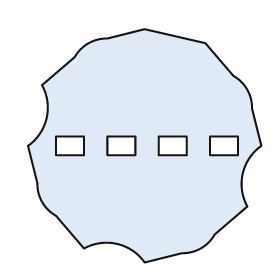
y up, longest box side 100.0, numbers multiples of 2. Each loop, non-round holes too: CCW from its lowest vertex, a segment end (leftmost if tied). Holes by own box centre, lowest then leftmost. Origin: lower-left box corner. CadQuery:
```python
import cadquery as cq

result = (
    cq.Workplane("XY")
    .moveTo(50.0, 0.0)
    .lineTo(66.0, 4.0)
    .threePointArc((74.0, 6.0), (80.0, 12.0))
    .lineTo(94.0, 24.0)
    .threePointArc((92.0, 38.0), (100.0, 50.0))
    .lineTo(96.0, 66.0)
    .threePointArc((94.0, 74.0), (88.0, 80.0))
    .lineTo(76.0, 94.0)
    .lineTo(50.0, 100.0)
    .lineTo(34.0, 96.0)
    .threePointArc((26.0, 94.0), (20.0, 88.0))
    .lineTo(6.0, 76.0)
    .threePointArc((8.0, 62.0), (0.0, 50.0))
    .lineTo(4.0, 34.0)
    .threePointArc((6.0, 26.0), (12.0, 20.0))
    .lineTo(24.0, 6.0)
    .threePointArc((38.0, 8.0), (50.0, 0.0))
    .close()
    .moveTo(12.0, 46.0)
    .lineTo(24.0, 46.0)
    .lineTo(24.0, 54.0)
    .lineTo(12.0, 54.0)
    .close()
    .moveTo(34.0, 46.0)
    .lineTo(46.0, 46.0)
    .lineTo(46.0, 54.0)
    .lineTo(34.0, 54.0)
    .close()
    .moveTo(56.0, 46.0)
    .lineTo(68.0, 46.0)
    .lineTo(68.0, 54.0)
    .lineTo(56.0, 54.0)
    .close()
    .moveTo(78.0, 46.0)
    .lineTo(90.0, 46.0)
    .lineTo(90.0, 54.0)
    .lineTo(78.0, 54.0)
    .close()
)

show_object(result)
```